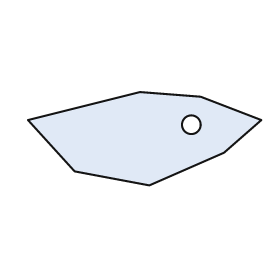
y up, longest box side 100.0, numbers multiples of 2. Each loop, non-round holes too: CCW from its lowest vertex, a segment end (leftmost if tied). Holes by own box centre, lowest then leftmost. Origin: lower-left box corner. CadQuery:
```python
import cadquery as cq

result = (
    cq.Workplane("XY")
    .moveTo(52.0, 0.0)
    .lineTo(84.0, 14.0)
    .lineTo(100.0, 28.0)
    .lineTo(74.0, 38.0)
    .lineTo(48.0, 40.0)
    .lineTo(0.0, 28.0)
    .lineTo(20.0, 6.0)
    .close()
    .moveTo(70.0, 26.0)
    .circle(4.0)
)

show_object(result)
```